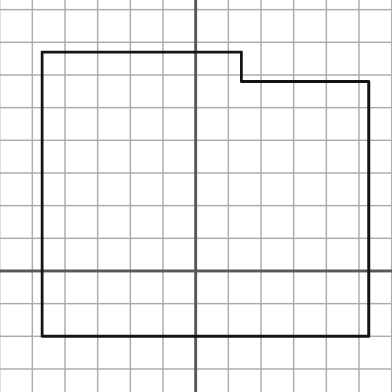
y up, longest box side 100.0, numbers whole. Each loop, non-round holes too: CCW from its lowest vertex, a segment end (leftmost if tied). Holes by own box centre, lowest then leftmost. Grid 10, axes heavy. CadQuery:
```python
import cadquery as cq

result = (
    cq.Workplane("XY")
    .moveTo(-47.0, -20.0)
    .lineTo(53.0, -20.0)
    .lineTo(53.0, 58.0)
    .lineTo(14.0, 58.0)
    .lineTo(14.0, 67.0)
    .lineTo(-47.0, 67.0)
    .close()
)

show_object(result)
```